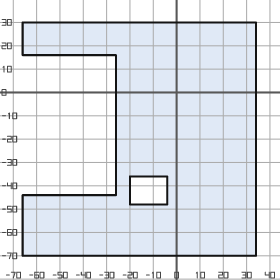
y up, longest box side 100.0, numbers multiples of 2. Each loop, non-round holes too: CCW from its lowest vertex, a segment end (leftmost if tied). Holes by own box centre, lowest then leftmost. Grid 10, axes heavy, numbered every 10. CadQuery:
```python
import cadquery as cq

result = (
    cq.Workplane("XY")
    .moveTo(-66.0, -70.0)
    .lineTo(34.0, -70.0)
    .lineTo(34.0, 30.0)
    .lineTo(-66.0, 30.0)
    .lineTo(-66.0, 16.0)
    .lineTo(-26.0, 16.0)
    .lineTo(-26.0, -44.0)
    .lineTo(-66.0, -44.0)
    .close()
    .moveTo(-20.0, -48.0)
    .lineTo(-4.0, -48.0)
    .lineTo(-4.0, -36.0)
    .lineTo(-20.0, -36.0)
    .close()
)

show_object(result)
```